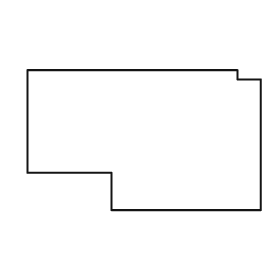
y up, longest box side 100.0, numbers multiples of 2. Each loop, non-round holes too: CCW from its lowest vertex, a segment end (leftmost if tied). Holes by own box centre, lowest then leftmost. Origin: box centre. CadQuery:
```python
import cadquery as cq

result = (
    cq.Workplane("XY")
    .moveTo(-14.0, -30.0)
    .lineTo(50.0, -30.0)
    .lineTo(50.0, 26.0)
    .lineTo(40.0, 26.0)
    .lineTo(40.0, 30.0)
    .lineTo(-50.0, 30.0)
    .lineTo(-50.0, -14.0)
    .lineTo(-14.0, -14.0)
    .close()
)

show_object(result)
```